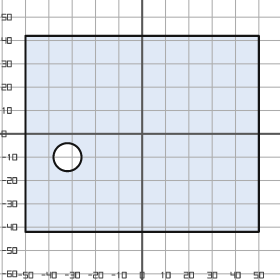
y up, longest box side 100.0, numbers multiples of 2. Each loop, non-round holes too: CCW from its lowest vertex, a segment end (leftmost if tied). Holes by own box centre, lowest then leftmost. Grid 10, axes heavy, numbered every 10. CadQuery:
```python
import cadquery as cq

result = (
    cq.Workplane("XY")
    .moveTo(-50.0, -42.0)
    .lineTo(50.0, -42.0)
    .lineTo(50.0, 42.0)
    .lineTo(-50.0, 42.0)
    .close()
    .moveTo(-32.0, -10.0)
    .circle(6.0)
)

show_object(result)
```